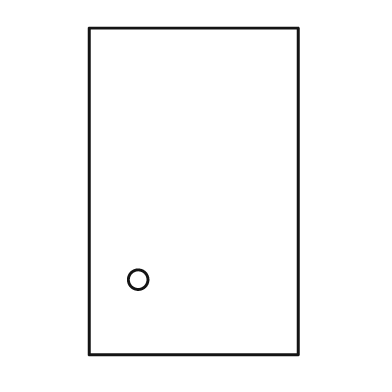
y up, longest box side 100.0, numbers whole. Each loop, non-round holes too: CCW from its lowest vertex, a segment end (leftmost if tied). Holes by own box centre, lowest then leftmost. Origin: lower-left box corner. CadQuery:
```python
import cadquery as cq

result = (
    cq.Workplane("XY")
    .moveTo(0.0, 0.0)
    .lineTo(64.0, 0.0)
    .lineTo(64.0, 100.0)
    .lineTo(0.0, 100.0)
    .close()
    .moveTo(15.0, 23.0)
    .circle(3.0)
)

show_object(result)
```